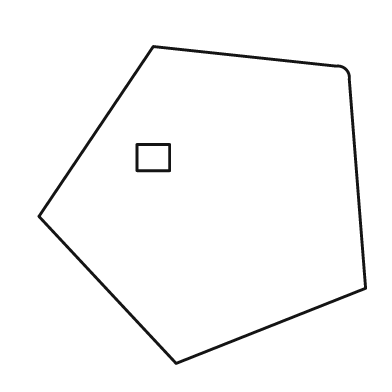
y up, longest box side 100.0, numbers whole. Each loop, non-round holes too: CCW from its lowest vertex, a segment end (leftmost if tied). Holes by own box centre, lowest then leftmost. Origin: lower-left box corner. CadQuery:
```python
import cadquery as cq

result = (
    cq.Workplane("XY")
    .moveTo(42.0, 0.0)
    .lineTo(100.0, 23.0)
    .lineTo(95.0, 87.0)
    .threePointArc((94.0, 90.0), (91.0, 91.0))
    .lineTo(35.0, 97.0)
    .lineTo(0.0, 45.0)
    .close()
    .moveTo(30.0, 59.0)
    .lineTo(40.0, 59.0)
    .lineTo(40.0, 67.0)
    .lineTo(30.0, 67.0)
    .close()
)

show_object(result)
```